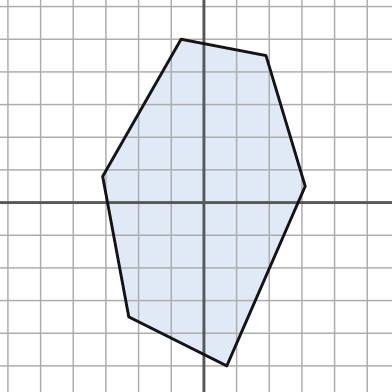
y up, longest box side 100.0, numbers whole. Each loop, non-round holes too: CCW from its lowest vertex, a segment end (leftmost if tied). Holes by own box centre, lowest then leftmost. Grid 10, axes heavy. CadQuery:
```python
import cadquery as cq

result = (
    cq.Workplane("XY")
    .moveTo(7.0, -50.0)
    .lineTo(31.0, 5.0)
    .lineTo(19.0, 45.0)
    .lineTo(-7.0, 50.0)
    .lineTo(-31.0, 8.0)
    .lineTo(-23.0, -35.0)
    .close()
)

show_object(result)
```